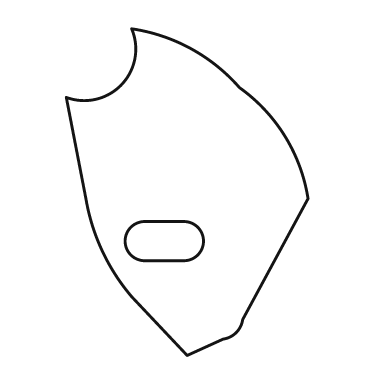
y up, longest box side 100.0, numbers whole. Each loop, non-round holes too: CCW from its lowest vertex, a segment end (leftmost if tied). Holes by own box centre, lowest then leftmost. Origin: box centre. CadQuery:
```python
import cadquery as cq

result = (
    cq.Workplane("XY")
    .moveTo(0.0, -50.0)
    .lineTo(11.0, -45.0)
    .threePointArc((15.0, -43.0), (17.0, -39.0))
    .lineTo(37.0, -2.0)
    .threePointArc((30.0, 17.0), (16.0, 32.0))
    .threePointArc((1.0, 44.0), (-17.0, 50.0))
    .threePointArc((-20.0, 33.0), (-37.0, 29.0))
    .lineTo(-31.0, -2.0)
    .threePointArc((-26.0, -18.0), (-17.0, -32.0))
    .close()
    .moveTo(-13.0, -21.0)
    .lineTo(-1.0, -21.0)
    .threePointArc((5.0, -15.0), (-1.0, -9.0))
    .lineTo(-13.0, -9.0)
    .threePointArc((-19.0, -15.0), (-13.0, -21.0))
    .close()
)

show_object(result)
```